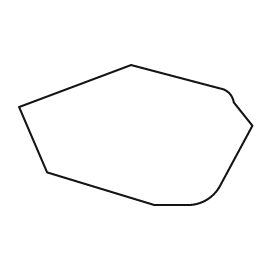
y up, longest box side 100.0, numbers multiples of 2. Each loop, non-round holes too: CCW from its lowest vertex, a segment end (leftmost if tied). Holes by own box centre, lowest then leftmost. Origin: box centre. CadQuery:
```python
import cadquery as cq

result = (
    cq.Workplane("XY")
    .moveTo(8.0, -30.0)
    .lineTo(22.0, -30.0)
    .threePointArc((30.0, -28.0), (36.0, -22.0))
    .lineTo(50.0, 4.0)
    .lineTo(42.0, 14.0)
    .threePointArc((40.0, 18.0), (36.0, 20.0))
    .lineTo(-2.0, 30.0)
    .lineTo(-50.0, 12.0)
    .lineTo(-38.0, -16.0)
    .close()
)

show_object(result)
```